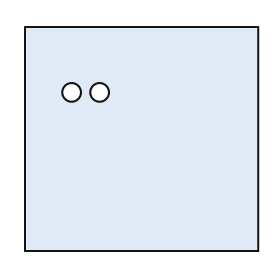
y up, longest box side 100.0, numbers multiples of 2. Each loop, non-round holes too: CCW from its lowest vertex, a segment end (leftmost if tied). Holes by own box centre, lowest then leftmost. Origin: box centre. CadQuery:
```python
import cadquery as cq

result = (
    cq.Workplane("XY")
    .moveTo(-50.0, -48.0)
    .lineTo(50.0, -48.0)
    .lineTo(50.0, 48.0)
    .lineTo(-50.0, 48.0)
    .close()
    .moveTo(-30.0, 20.0)
    .circle(4.0)
    .moveTo(-18.0, 20.0)
    .circle(4.0)
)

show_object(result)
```